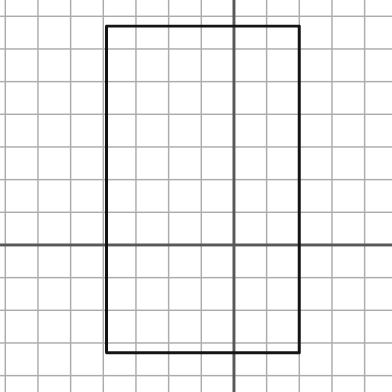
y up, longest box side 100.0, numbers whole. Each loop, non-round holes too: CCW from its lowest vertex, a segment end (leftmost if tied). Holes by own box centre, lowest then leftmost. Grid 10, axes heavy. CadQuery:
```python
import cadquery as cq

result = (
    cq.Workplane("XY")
    .moveTo(-39.0, -33.0)
    .lineTo(20.0, -33.0)
    .lineTo(20.0, 67.0)
    .lineTo(-39.0, 67.0)
    .close()
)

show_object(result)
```